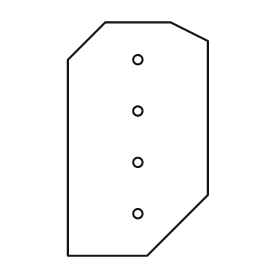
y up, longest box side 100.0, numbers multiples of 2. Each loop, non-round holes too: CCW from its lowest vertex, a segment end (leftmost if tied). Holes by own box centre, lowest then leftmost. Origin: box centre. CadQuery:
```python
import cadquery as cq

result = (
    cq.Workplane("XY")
    .moveTo(-30.0, -50.0)
    .lineTo(4.0, -50.0)
    .lineTo(30.0, -24.0)
    .lineTo(30.0, 42.0)
    .lineTo(14.0, 50.0)
    .lineTo(-14.0, 50.0)
    .lineTo(-30.0, 34.0)
    .close()
    .moveTo(0.0, -32.0)
    .circle(2.0)
    .moveTo(0.0, -10.0)
    .circle(2.0)
    .moveTo(0.0, 12.0)
    .circle(2.0)
    .moveTo(0.0, 34.0)
    .circle(2.0)
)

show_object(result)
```